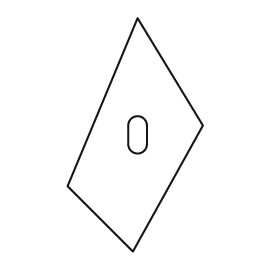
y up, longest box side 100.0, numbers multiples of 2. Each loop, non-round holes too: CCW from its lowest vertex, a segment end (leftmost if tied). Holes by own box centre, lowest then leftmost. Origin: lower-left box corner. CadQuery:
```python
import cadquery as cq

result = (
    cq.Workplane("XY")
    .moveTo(28.0, 0.0)
    .lineTo(58.0, 54.0)
    .lineTo(30.0, 100.0)
    .lineTo(0.0, 28.0)
    .close()
    .moveTo(26.0, 46.0)
    .threePointArc((30.0, 42.0), (34.0, 46.0))
    .lineTo(34.0, 54.0)
    .threePointArc((30.0, 58.0), (26.0, 54.0))
    .close()
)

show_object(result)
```